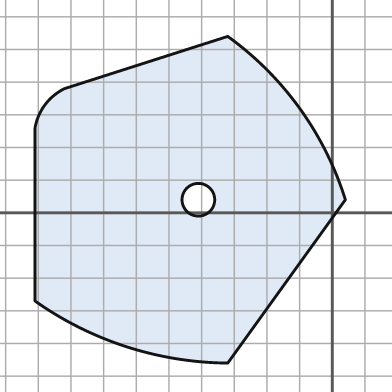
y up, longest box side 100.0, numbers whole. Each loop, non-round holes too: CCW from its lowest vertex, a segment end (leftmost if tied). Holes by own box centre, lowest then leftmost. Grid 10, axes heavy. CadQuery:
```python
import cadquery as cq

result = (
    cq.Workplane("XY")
    .moveTo(-32.0, -46.0)
    .lineTo(4.0, 4.0)
    .threePointArc((-10.0, 32.0), (-32.0, 54.0))
    .lineTo(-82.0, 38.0)
    .threePointArc((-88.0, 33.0), (-91.0, 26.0))
    .lineTo(-91.0, -27.0)
    .threePointArc((-63.0, -41.0), (-32.0, -46.0))
    .close()
    .moveTo(-41.0, 4.0)
    .circle(5.0)
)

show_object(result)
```